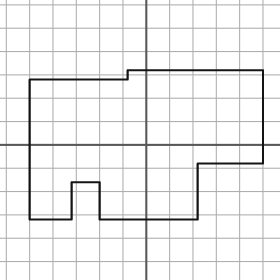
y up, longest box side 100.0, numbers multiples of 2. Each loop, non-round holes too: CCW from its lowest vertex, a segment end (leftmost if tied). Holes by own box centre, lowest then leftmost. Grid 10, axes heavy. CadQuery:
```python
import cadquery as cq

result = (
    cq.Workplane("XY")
    .moveTo(-50.0, -32.0)
    .lineTo(-32.0, -32.0)
    .lineTo(-32.0, -16.0)
    .lineTo(-20.0, -16.0)
    .lineTo(-20.0, -32.0)
    .lineTo(22.0, -32.0)
    .lineTo(22.0, -8.0)
    .lineTo(50.0, -8.0)
    .lineTo(50.0, 32.0)
    .lineTo(-8.0, 32.0)
    .lineTo(-8.0, 28.0)
    .lineTo(-50.0, 28.0)
    .close()
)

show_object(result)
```